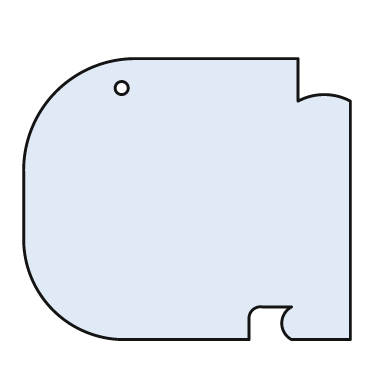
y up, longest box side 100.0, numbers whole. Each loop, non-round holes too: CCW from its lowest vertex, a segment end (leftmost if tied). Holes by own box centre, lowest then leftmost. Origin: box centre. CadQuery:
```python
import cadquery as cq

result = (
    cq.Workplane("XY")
    .moveTo(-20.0, -43.0)
    .lineTo(19.0, -43.0)
    .lineTo(19.0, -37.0)
    .threePointArc((20.0, -34.0), (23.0, -33.0))
    .lineTo(32.0, -33.0)
    .threePointArc((29.0, -38.0), (32.0, -43.0))
    .lineTo(50.0, -43.0)
    .lineTo(50.0, 30.0)
    .threePointArc((42.0, 32.0), (34.0, 30.0))
    .lineTo(34.0, 43.0)
    .lineTo(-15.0, 43.0)
    .threePointArc((-40.0, 33.0), (-50.0, 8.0))
    .lineTo(-50.0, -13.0)
    .threePointArc((-41.0, -34.0), (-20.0, -43.0))
    .close()
    .moveTo(-20.0, 34.0)
    .circle(2.0)
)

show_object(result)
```